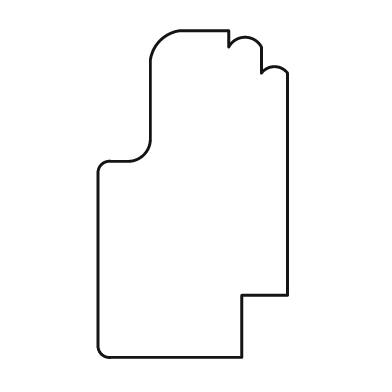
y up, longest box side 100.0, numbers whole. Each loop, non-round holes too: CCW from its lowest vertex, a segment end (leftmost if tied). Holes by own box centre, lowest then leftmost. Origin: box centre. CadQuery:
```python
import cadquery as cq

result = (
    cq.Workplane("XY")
    .moveTo(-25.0, -50.0)
    .lineTo(15.0, -50.0)
    .lineTo(15.0, -31.0)
    .lineTo(29.0, -31.0)
    .lineTo(29.0, 37.0)
    .threePointArc((25.0, 39.0), (21.0, 37.0))
    .lineTo(21.0, 45.0)
    .threePointArc((16.0, 48.0), (11.0, 45.0))
    .lineTo(11.0, 50.0)
    .lineTo(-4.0, 50.0)
    .threePointArc((-10.0, 47.0), (-13.0, 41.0))
    .lineTo(-13.0, 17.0)
    .threePointArc((-15.0, 12.0), (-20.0, 10.0))
    .lineTo(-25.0, 10.0)
    .threePointArc((-28.0, 9.0), (-29.0, 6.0))
    .lineTo(-29.0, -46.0)
    .threePointArc((-28.0, -49.0), (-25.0, -50.0))
    .close()
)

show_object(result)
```